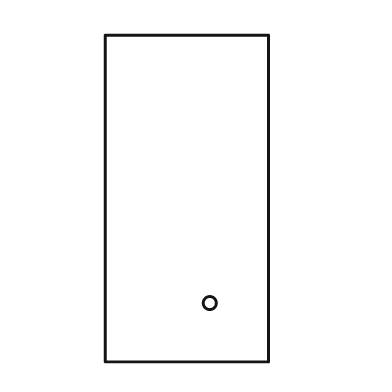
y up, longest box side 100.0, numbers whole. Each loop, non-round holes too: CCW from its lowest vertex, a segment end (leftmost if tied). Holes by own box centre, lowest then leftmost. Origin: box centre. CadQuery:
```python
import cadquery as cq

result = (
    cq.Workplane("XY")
    .moveTo(-25.0, -50.0)
    .lineTo(25.0, -50.0)
    .lineTo(25.0, 50.0)
    .lineTo(-25.0, 50.0)
    .close()
    .moveTo(7.0, -32.0)
    .circle(2.0)
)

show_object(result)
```